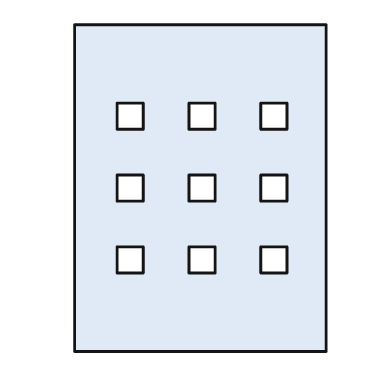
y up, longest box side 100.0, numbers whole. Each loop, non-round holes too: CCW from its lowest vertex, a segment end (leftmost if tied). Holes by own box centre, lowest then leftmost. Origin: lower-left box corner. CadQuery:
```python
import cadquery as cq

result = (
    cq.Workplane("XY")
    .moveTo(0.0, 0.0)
    .lineTo(77.0, 0.0)
    .lineTo(77.0, 100.0)
    .lineTo(0.0, 100.0)
    .close()
    .moveTo(13.0, 24.0)
    .lineTo(21.0, 24.0)
    .lineTo(21.0, 32.0)
    .lineTo(13.0, 32.0)
    .close()
    .moveTo(35.0, 24.0)
    .lineTo(43.0, 24.0)
    .lineTo(43.0, 32.0)
    .lineTo(35.0, 32.0)
    .close()
    .moveTo(57.0, 24.0)
    .lineTo(65.0, 24.0)
    .lineTo(65.0, 32.0)
    .lineTo(57.0, 32.0)
    .close()
    .moveTo(13.0, 46.0)
    .lineTo(21.0, 46.0)
    .lineTo(21.0, 54.0)
    .lineTo(13.0, 54.0)
    .close()
    .moveTo(35.0, 46.0)
    .lineTo(43.0, 46.0)
    .lineTo(43.0, 54.0)
    .lineTo(35.0, 54.0)
    .close()
    .moveTo(57.0, 46.0)
    .lineTo(65.0, 46.0)
    .lineTo(65.0, 54.0)
    .lineTo(57.0, 54.0)
    .close()
    .moveTo(13.0, 68.0)
    .lineTo(21.0, 68.0)
    .lineTo(21.0, 76.0)
    .lineTo(13.0, 76.0)
    .close()
    .moveTo(35.0, 68.0)
    .lineTo(43.0, 68.0)
    .lineTo(43.0, 76.0)
    .lineTo(35.0, 76.0)
    .close()
    .moveTo(57.0, 68.0)
    .lineTo(65.0, 68.0)
    .lineTo(65.0, 76.0)
    .lineTo(57.0, 76.0)
    .close()
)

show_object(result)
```